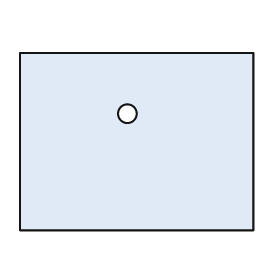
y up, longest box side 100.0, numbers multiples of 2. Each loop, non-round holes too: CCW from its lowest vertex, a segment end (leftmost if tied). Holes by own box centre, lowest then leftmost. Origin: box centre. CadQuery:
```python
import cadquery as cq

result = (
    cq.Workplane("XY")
    .moveTo(-50.0, -38.0)
    .lineTo(50.0, -38.0)
    .lineTo(50.0, 38.0)
    .lineTo(-50.0, 38.0)
    .close()
    .moveTo(-4.0, 12.0)
    .circle(4.0)
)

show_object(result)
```